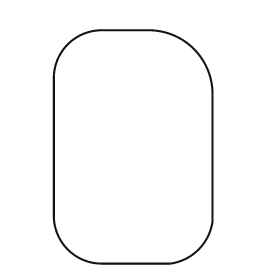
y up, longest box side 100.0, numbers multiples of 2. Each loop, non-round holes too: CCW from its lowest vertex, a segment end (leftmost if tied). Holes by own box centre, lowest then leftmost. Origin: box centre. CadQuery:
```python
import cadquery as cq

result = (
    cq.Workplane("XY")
    .moveTo(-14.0, -50.0)
    .lineTo(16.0, -50.0)
    .threePointArc((28.0, -44.0), (34.0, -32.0))
    .lineTo(34.0, 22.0)
    .threePointArc((26.0, 42.0), (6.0, 50.0))
    .lineTo(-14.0, 50.0)
    .threePointArc((-28.0, 44.0), (-34.0, 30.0))
    .lineTo(-34.0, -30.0)
    .threePointArc((-28.0, -44.0), (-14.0, -50.0))
    .close()
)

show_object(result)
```